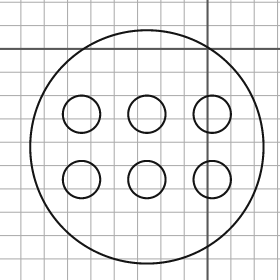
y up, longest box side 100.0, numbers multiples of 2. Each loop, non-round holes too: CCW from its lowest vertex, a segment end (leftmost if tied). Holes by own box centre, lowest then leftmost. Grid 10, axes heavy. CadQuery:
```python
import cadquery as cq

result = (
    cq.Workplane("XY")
    .moveTo(-26.0, -42.0)
    .circle(50.0)
    .moveTo(-54.0, -56.0)
    .circle(8.0)
    .moveTo(-26.0, -56.0)
    .circle(8.0)
    .moveTo(2.0, -56.0)
    .circle(8.0)
    .moveTo(-54.0, -28.0)
    .circle(8.0)
    .moveTo(-26.0, -28.0)
    .circle(8.0)
    .moveTo(2.0, -28.0)
    .circle(8.0)
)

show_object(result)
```